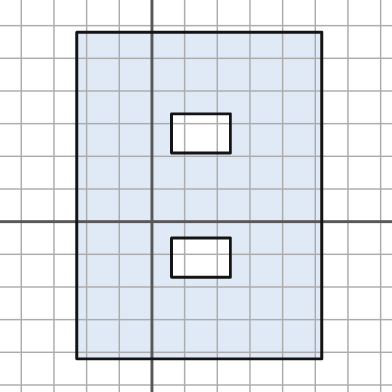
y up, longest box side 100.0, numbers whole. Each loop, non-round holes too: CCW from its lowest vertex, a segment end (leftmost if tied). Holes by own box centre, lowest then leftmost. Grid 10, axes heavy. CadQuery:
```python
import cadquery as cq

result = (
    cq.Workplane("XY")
    .moveTo(-23.0, -42.0)
    .lineTo(52.0, -42.0)
    .lineTo(52.0, 58.0)
    .lineTo(-23.0, 58.0)
    .close()
    .moveTo(6.0, -17.0)
    .lineTo(24.0, -17.0)
    .lineTo(24.0, -5.0)
    .lineTo(6.0, -5.0)
    .close()
    .moveTo(6.0, 21.0)
    .lineTo(24.0, 21.0)
    .lineTo(24.0, 33.0)
    .lineTo(6.0, 33.0)
    .close()
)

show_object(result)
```